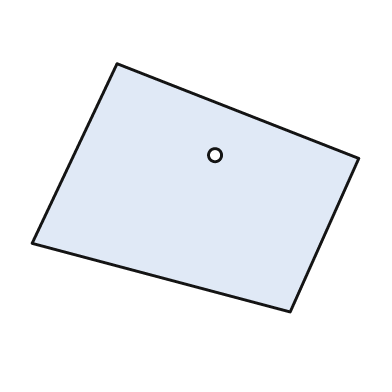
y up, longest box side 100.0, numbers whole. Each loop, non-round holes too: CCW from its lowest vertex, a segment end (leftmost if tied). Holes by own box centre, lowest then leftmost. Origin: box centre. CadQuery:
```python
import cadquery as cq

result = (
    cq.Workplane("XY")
    .moveTo(29.0, -38.0)
    .lineTo(50.0, 9.0)
    .lineTo(-24.0, 38.0)
    .lineTo(-50.0, -17.0)
    .close()
    .moveTo(6.0, 10.0)
    .circle(2.0)
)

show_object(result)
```